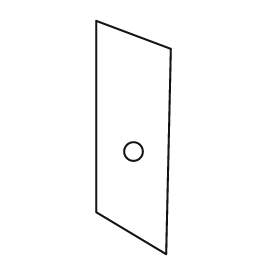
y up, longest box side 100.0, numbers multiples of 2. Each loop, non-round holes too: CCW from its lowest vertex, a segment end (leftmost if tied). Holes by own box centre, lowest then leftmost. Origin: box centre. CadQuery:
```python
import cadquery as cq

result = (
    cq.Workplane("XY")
    .moveTo(14.0, -50.0)
    .lineTo(16.0, 38.0)
    .lineTo(-16.0, 50.0)
    .lineTo(-16.0, -32.0)
    .close()
    .moveTo(0.0, -6.0)
    .circle(4.0)
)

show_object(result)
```